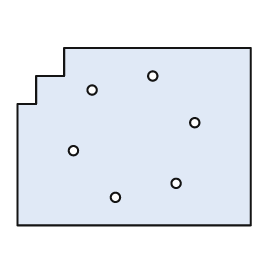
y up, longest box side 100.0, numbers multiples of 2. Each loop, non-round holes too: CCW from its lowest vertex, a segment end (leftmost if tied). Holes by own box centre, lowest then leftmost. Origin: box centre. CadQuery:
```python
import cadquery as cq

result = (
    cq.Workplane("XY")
    .moveTo(-50.0, -38.0)
    .lineTo(50.0, -38.0)
    .lineTo(50.0, 38.0)
    .lineTo(-30.0, 38.0)
    .lineTo(-30.0, 26.0)
    .lineTo(-42.0, 26.0)
    .lineTo(-42.0, 14.0)
    .lineTo(-50.0, 14.0)
    .close()
    .moveTo(-8.0, -26.0)
    .circle(2.0)
    .moveTo(18.0, -20.0)
    .circle(2.0)
    .moveTo(-26.0, -6.0)
    .circle(2.0)
    .moveTo(26.0, 6.0)
    .circle(2.0)
    .moveTo(-18.0, 20.0)
    .circle(2.0)
    .moveTo(8.0, 26.0)
    .circle(2.0)
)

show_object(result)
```